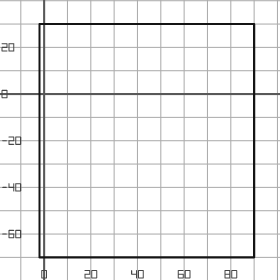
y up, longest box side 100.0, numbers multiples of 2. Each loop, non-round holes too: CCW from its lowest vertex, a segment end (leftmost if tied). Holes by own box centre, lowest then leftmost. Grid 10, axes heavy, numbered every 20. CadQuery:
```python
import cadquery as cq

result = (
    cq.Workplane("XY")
    .moveTo(-2.0, -70.0)
    .lineTo(90.0, -70.0)
    .lineTo(90.0, 30.0)
    .lineTo(-2.0, 30.0)
    .close()
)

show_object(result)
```